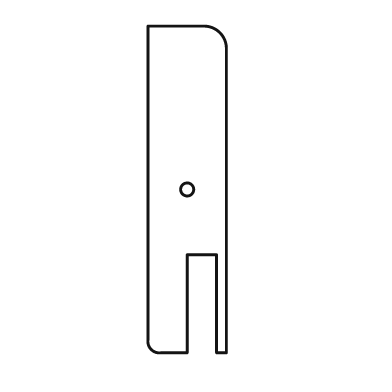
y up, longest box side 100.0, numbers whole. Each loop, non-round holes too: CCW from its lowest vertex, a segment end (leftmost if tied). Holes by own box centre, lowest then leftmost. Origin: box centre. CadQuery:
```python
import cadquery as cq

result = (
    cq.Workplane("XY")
    .moveTo(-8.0, -50.0)
    .lineTo(0.0, -50.0)
    .lineTo(0.0, -20.0)
    .lineTo(9.0, -20.0)
    .lineTo(9.0, -50.0)
    .lineTo(12.0, -50.0)
    .lineTo(12.0, 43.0)
    .threePointArc((10.0, 48.0), (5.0, 50.0))
    .lineTo(-12.0, 50.0)
    .lineTo(-12.0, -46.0)
    .threePointArc((-11.0, -49.0), (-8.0, -50.0))
    .close()
    .moveTo(0.0, 0.0)
    .circle(2.0)
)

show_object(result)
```